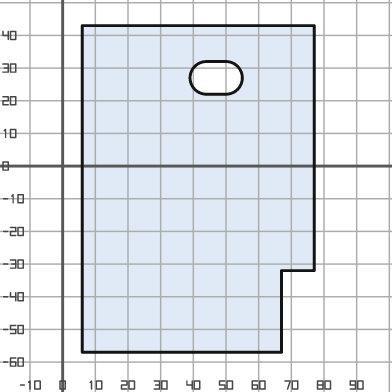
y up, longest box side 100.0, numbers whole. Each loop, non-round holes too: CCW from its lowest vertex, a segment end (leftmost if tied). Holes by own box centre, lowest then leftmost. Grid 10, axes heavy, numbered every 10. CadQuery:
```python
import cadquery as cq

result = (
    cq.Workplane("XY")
    .moveTo(6.0, -57.0)
    .lineTo(67.0, -57.0)
    .lineTo(67.0, -32.0)
    .lineTo(77.0, -32.0)
    .lineTo(77.0, 43.0)
    .lineTo(6.0, 43.0)
    .close()
    .moveTo(44.0, 22.0)
    .lineTo(50.0, 22.0)
    .threePointArc((55.0, 27.0), (50.0, 32.0))
    .lineTo(44.0, 32.0)
    .threePointArc((39.0, 27.0), (44.0, 22.0))
    .close()
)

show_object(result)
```